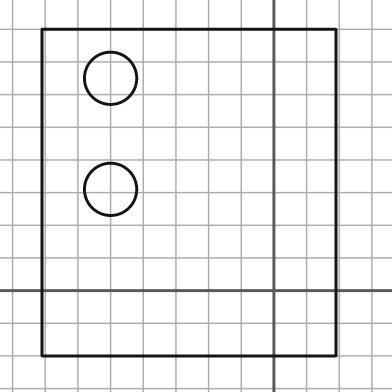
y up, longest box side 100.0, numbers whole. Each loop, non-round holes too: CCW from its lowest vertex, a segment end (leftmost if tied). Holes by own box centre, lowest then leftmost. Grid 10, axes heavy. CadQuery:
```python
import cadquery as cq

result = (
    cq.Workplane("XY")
    .moveTo(-71.0, -20.0)
    .lineTo(19.0, -20.0)
    .lineTo(19.0, 80.0)
    .lineTo(-71.0, 80.0)
    .close()
    .moveTo(-50.0, 31.0)
    .circle(8.0)
    .moveTo(-50.0, 65.0)
    .circle(8.0)
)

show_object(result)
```